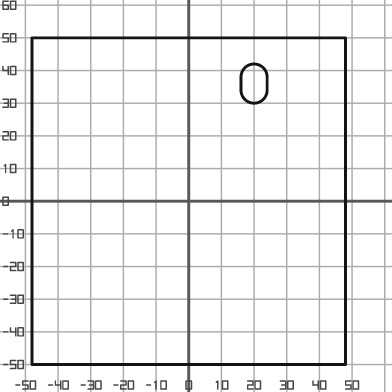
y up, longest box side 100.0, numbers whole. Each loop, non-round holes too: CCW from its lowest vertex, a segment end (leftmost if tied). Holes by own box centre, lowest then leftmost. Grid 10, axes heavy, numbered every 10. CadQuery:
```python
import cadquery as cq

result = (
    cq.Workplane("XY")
    .moveTo(-48.0, -50.0)
    .lineTo(48.0, -50.0)
    .lineTo(48.0, 50.0)
    .lineTo(-48.0, 50.0)
    .close()
    .moveTo(16.0, 34.0)
    .threePointArc((20.0, 30.0), (24.0, 34.0))
    .lineTo(24.0, 38.0)
    .threePointArc((20.0, 42.0), (16.0, 38.0))
    .close()
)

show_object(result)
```